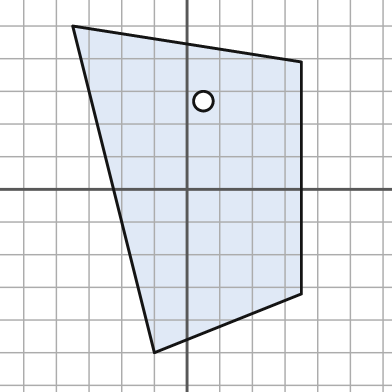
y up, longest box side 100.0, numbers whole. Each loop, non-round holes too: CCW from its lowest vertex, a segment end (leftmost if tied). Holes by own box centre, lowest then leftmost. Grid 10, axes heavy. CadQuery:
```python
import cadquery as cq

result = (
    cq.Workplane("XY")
    .moveTo(-10.0, -50.0)
    .lineTo(35.0, -32.0)
    .lineTo(35.0, 39.0)
    .lineTo(-35.0, 50.0)
    .close()
    .moveTo(5.0, 27.0)
    .circle(3.0)
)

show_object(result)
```